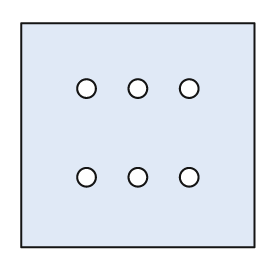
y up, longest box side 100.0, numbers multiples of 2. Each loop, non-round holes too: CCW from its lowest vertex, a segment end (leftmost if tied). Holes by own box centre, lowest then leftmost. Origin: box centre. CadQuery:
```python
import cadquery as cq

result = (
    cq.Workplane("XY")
    .moveTo(-50.0, -48.0)
    .lineTo(50.0, -48.0)
    .lineTo(50.0, 48.0)
    .lineTo(-50.0, 48.0)
    .close()
    .moveTo(-22.0, -18.0)
    .circle(4.0)
    .moveTo(0.0, -18.0)
    .circle(4.0)
    .moveTo(22.0, -18.0)
    .circle(4.0)
    .moveTo(-22.0, 20.0)
    .circle(4.0)
    .moveTo(0.0, 20.0)
    .circle(4.0)
    .moveTo(22.0, 20.0)
    .circle(4.0)
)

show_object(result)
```